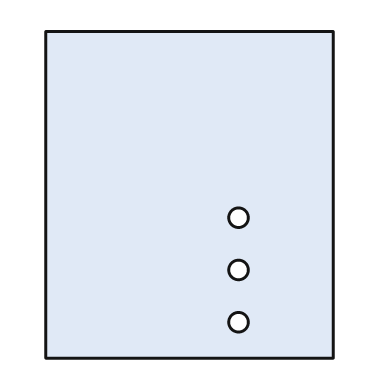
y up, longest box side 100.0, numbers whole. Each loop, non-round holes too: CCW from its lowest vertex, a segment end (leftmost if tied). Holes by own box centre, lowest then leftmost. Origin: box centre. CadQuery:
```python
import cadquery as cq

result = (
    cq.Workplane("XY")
    .moveTo(-44.0, -50.0)
    .lineTo(44.0, -50.0)
    .lineTo(44.0, 50.0)
    .lineTo(-44.0, 50.0)
    .close()
    .moveTo(15.0, -39.0)
    .circle(3.0)
    .moveTo(15.0, -23.0)
    .circle(3.0)
    .moveTo(15.0, -7.0)
    .circle(3.0)
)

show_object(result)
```